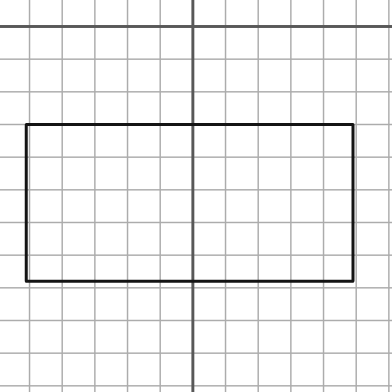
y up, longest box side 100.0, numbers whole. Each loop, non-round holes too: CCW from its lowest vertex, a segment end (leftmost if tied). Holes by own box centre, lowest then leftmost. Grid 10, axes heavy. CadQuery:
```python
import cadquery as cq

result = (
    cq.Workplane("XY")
    .moveTo(-51.0, -78.0)
    .lineTo(49.0, -78.0)
    .lineTo(49.0, -30.0)
    .lineTo(-51.0, -30.0)
    .close()
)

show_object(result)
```